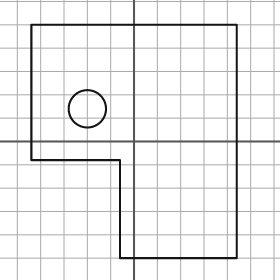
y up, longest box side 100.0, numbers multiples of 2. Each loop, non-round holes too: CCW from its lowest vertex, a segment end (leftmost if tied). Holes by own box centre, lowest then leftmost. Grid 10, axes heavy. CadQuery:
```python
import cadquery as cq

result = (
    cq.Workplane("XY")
    .moveTo(-6.0, -50.0)
    .lineTo(44.0, -50.0)
    .lineTo(44.0, 50.0)
    .lineTo(-44.0, 50.0)
    .lineTo(-44.0, -8.0)
    .lineTo(-6.0, -8.0)
    .close()
    .moveTo(-20.0, 14.0)
    .circle(8.0)
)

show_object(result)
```